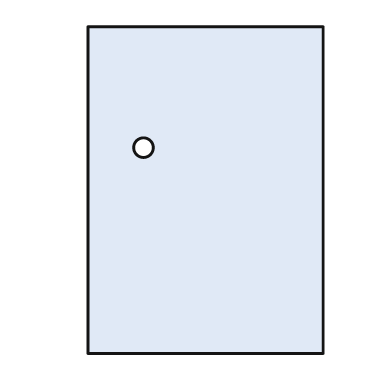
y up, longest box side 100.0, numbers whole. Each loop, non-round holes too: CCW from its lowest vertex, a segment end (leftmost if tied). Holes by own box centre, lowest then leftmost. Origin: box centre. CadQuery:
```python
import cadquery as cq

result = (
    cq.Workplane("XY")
    .moveTo(-36.0, -50.0)
    .lineTo(36.0, -50.0)
    .lineTo(36.0, 50.0)
    .lineTo(-36.0, 50.0)
    .close()
    .moveTo(-19.0, 13.0)
    .circle(3.0)
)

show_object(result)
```